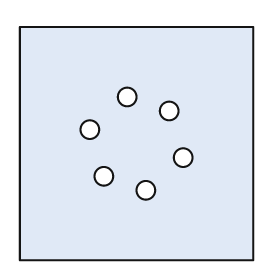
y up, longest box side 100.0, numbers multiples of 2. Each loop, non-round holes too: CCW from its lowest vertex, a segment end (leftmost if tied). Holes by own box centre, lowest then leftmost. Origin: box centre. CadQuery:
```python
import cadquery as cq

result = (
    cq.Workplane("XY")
    .moveTo(-50.0, -50.0)
    .lineTo(50.0, -50.0)
    .lineTo(50.0, 50.0)
    .lineTo(-50.0, 50.0)
    .close()
    .moveTo(4.0, -20.0)
    .circle(4.0)
    .moveTo(-14.0, -14.0)
    .circle(4.0)
    .moveTo(20.0, -6.0)
    .circle(4.0)
    .moveTo(-20.0, 6.0)
    .circle(4.0)
    .moveTo(14.0, 14.0)
    .circle(4.0)
    .moveTo(-4.0, 20.0)
    .circle(4.0)
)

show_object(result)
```